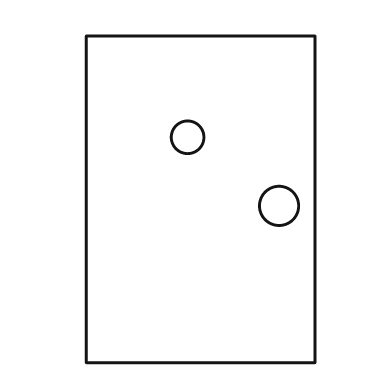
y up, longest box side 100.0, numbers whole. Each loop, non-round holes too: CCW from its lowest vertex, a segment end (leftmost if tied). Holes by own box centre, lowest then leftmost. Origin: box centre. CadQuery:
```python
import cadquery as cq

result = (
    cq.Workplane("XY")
    .moveTo(-35.0, -50.0)
    .lineTo(35.0, -50.0)
    .lineTo(35.0, 50.0)
    .lineTo(-35.0, 50.0)
    .close()
    .moveTo(24.0, -2.0)
    .circle(6.0)
    .moveTo(-4.0, 19.0)
    .circle(5.0)
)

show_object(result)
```